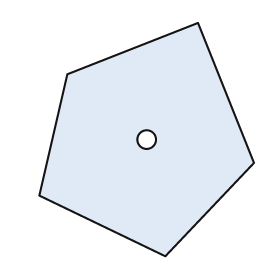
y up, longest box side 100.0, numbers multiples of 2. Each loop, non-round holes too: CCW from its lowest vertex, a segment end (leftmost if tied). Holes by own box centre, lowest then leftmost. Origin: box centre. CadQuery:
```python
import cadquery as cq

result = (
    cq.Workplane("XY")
    .moveTo(8.0, -50.0)
    .lineTo(46.0, -10.0)
    .lineTo(22.0, 50.0)
    .lineTo(-34.0, 28.0)
    .lineTo(-46.0, -24.0)
    .close()
    .moveTo(0.0, 0.0)
    .circle(4.0)
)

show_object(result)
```